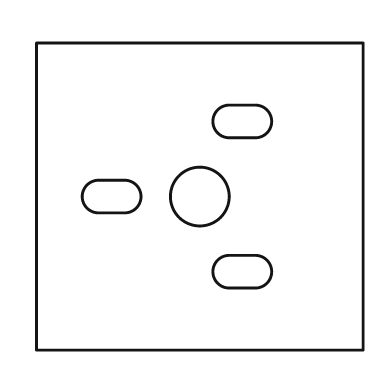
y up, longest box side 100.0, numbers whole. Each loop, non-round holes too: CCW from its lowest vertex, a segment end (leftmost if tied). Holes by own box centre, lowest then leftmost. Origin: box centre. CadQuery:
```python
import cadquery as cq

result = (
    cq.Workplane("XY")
    .moveTo(-50.0, -47.0)
    .lineTo(50.0, -47.0)
    .lineTo(50.0, 47.0)
    .lineTo(-50.0, 47.0)
    .close()
    .moveTo(9.0, -28.0)
    .lineTo(17.0, -28.0)
    .threePointArc((22.0, -23.0), (17.0, -18.0))
    .lineTo(9.0, -18.0)
    .threePointArc((4.0, -23.0), (9.0, -28.0))
    .close()
    .moveTo(-31.0, -5.0)
    .lineTo(-23.0, -5.0)
    .threePointArc((-18.0, 0.0), (-23.0, 5.0))
    .lineTo(-31.0, 5.0)
    .threePointArc((-36.0, 0.0), (-31.0, -5.0))
    .close()
    .moveTo(0.0, 0.0)
    .circle(9.0)
    .moveTo(9.0, 18.0)
    .lineTo(17.0, 18.0)
    .threePointArc((22.0, 23.0), (17.0, 28.0))
    .lineTo(9.0, 28.0)
    .threePointArc((4.0, 23.0), (9.0, 18.0))
    .close()
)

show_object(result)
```